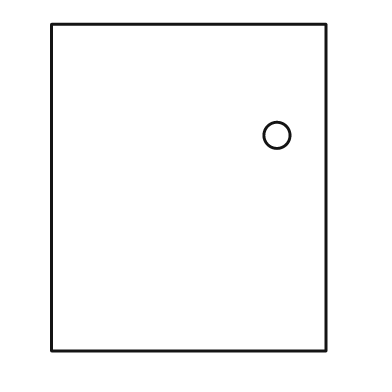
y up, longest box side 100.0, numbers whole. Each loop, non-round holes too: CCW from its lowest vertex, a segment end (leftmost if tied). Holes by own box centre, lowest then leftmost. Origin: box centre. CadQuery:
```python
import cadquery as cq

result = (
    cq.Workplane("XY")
    .moveTo(-42.0, -50.0)
    .lineTo(42.0, -50.0)
    .lineTo(42.0, 50.0)
    .lineTo(-42.0, 50.0)
    .close()
    .moveTo(27.0, 16.0)
    .circle(4.0)
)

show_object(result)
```